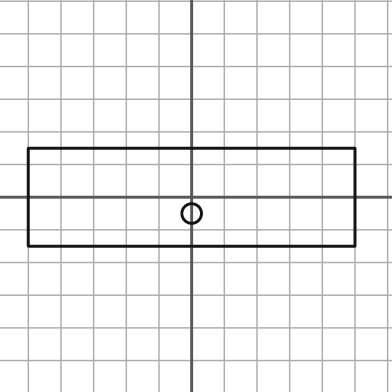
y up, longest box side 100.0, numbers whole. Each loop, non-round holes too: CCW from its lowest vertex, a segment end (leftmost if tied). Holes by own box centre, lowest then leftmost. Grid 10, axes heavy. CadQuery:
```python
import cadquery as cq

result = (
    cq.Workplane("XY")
    .moveTo(-50.0, -15.0)
    .lineTo(50.0, -15.0)
    .lineTo(50.0, 15.0)
    .lineTo(-50.0, 15.0)
    .close()
    .moveTo(0.0, -5.0)
    .circle(3.0)
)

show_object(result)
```